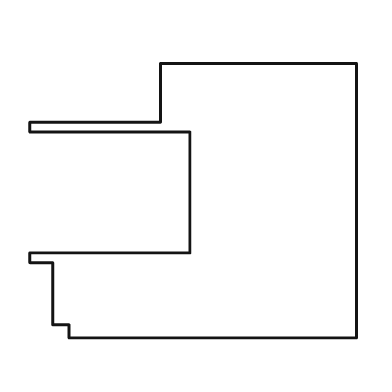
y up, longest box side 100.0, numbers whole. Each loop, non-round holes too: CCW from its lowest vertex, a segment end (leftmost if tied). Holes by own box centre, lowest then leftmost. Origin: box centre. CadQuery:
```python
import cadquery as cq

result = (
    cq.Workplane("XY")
    .moveTo(-38.0, -42.0)
    .lineTo(50.0, -42.0)
    .lineTo(50.0, 42.0)
    .lineTo(-10.0, 42.0)
    .lineTo(-10.0, 24.0)
    .lineTo(-50.0, 24.0)
    .lineTo(-50.0, 21.0)
    .lineTo(-1.0, 21.0)
    .lineTo(-1.0, -16.0)
    .lineTo(-50.0, -16.0)
    .lineTo(-50.0, -19.0)
    .lineTo(-43.0, -19.0)
    .lineTo(-43.0, -38.0)
    .lineTo(-38.0, -38.0)
    .close()
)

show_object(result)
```